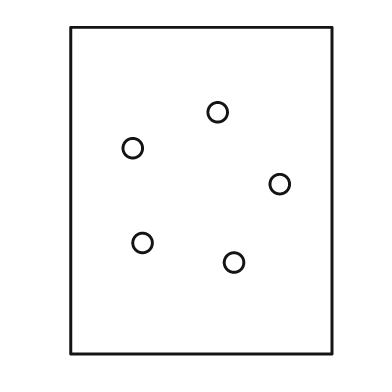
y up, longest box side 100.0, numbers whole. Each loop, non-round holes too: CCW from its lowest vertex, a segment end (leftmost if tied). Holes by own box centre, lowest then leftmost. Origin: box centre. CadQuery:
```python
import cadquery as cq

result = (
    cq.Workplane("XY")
    .moveTo(-40.0, -50.0)
    .lineTo(40.0, -50.0)
    .lineTo(40.0, 50.0)
    .lineTo(-40.0, 50.0)
    .close()
    .moveTo(10.0, -22.0)
    .circle(3.0)
    .moveTo(-18.0, -16.0)
    .circle(3.0)
    .moveTo(24.0, 2.0)
    .circle(3.0)
    .moveTo(-21.0, 13.0)
    .circle(3.0)
    .moveTo(5.0, 24.0)
    .circle(3.0)
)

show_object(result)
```